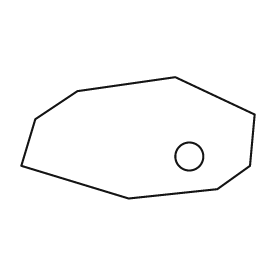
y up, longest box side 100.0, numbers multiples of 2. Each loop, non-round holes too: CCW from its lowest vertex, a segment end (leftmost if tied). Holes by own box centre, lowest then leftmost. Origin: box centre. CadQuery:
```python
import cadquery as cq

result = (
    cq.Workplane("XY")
    .moveTo(-4.0, -26.0)
    .lineTo(34.0, -22.0)
    .lineTo(48.0, -12.0)
    .lineTo(50.0, 10.0)
    .lineTo(16.0, 26.0)
    .lineTo(-26.0, 20.0)
    .lineTo(-44.0, 8.0)
    .lineTo(-50.0, -12.0)
    .close()
    .moveTo(22.0, -8.0)
    .circle(6.0)
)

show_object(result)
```